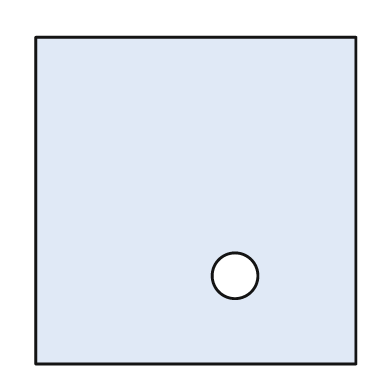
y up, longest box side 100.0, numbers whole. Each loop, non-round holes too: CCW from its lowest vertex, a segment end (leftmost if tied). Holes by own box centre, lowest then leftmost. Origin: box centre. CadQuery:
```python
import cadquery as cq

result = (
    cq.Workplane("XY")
    .moveTo(-49.0, -50.0)
    .lineTo(49.0, -50.0)
    .lineTo(49.0, 50.0)
    .lineTo(-49.0, 50.0)
    .close()
    .moveTo(12.0, -23.0)
    .circle(7.0)
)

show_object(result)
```